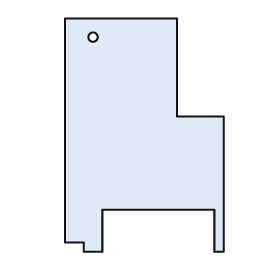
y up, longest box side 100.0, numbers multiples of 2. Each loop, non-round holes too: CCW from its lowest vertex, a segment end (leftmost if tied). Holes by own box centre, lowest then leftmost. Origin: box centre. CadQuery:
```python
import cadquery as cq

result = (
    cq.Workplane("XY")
    .moveTo(-26.0, -50.0)
    .lineTo(-18.0, -50.0)
    .lineTo(-18.0, -32.0)
    .lineTo(30.0, -32.0)
    .lineTo(30.0, -50.0)
    .lineTo(34.0, -50.0)
    .lineTo(34.0, 8.0)
    .lineTo(14.0, 8.0)
    .lineTo(14.0, 50.0)
    .lineTo(-34.0, 50.0)
    .lineTo(-34.0, -46.0)
    .lineTo(-26.0, -46.0)
    .close()
    .moveTo(-22.0, 42.0)
    .circle(2.0)
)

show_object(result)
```